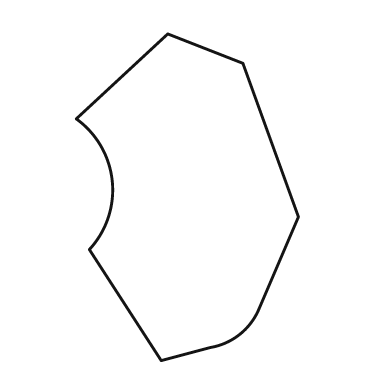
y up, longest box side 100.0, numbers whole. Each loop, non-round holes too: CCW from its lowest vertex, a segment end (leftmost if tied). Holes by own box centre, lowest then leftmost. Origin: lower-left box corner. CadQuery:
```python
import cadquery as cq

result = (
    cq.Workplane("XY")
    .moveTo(26.0, 0.0)
    .lineTo(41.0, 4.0)
    .threePointArc((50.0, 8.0), (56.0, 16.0))
    .lineTo(68.0, 44.0)
    .lineTo(51.0, 91.0)
    .lineTo(28.0, 100.0)
    .lineTo(0.0, 74.0)
    .threePointArc((11.0, 55.0), (4.0, 34.0))
    .close()
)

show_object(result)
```